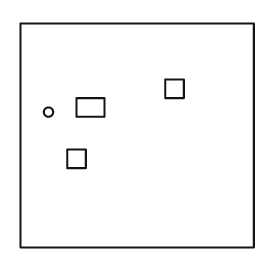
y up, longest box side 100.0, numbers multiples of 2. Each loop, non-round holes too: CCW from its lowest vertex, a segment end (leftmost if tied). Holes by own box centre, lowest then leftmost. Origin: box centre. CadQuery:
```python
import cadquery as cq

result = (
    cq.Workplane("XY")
    .moveTo(-50.0, -48.0)
    .lineTo(50.0, -48.0)
    .lineTo(50.0, 48.0)
    .lineTo(-50.0, 48.0)
    .close()
    .moveTo(-30.0, -14.0)
    .lineTo(-22.0, -14.0)
    .lineTo(-22.0, -6.0)
    .lineTo(-30.0, -6.0)
    .close()
    .moveTo(-38.0, 10.0)
    .circle(2.0)
    .moveTo(-26.0, 8.0)
    .lineTo(-14.0, 8.0)
    .lineTo(-14.0, 16.0)
    .lineTo(-26.0, 16.0)
    .close()
    .moveTo(12.0, 16.0)
    .lineTo(20.0, 16.0)
    .lineTo(20.0, 24.0)
    .lineTo(12.0, 24.0)
    .close()
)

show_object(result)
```